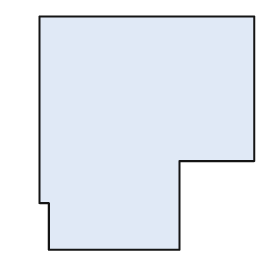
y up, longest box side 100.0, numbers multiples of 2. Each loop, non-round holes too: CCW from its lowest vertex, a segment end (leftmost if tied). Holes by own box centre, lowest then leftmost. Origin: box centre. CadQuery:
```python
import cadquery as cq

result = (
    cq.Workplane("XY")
    .moveTo(-42.0, -50.0)
    .lineTo(14.0, -50.0)
    .lineTo(14.0, -12.0)
    .lineTo(46.0, -12.0)
    .lineTo(46.0, 50.0)
    .lineTo(-46.0, 50.0)
    .lineTo(-46.0, -30.0)
    .lineTo(-42.0, -30.0)
    .close()
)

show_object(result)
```